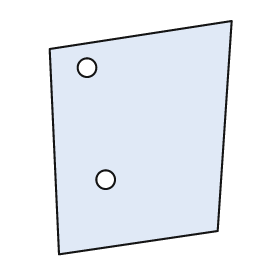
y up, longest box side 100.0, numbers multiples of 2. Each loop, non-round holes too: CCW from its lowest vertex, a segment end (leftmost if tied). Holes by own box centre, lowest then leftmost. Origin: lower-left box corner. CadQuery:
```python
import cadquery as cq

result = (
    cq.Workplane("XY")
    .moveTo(4.0, 0.0)
    .lineTo(72.0, 10.0)
    .lineTo(78.0, 100.0)
    .lineTo(0.0, 88.0)
    .close()
    .moveTo(24.0, 32.0)
    .circle(4.0)
    .moveTo(16.0, 80.0)
    .circle(4.0)
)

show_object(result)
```